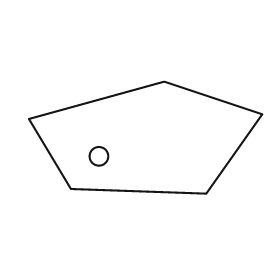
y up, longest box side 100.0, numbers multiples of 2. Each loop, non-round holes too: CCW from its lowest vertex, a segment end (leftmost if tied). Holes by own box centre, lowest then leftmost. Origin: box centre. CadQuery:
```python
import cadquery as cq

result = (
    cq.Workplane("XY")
    .moveTo(26.0, -24.0)
    .lineTo(50.0, 10.0)
    .lineTo(8.0, 24.0)
    .lineTo(-50.0, 8.0)
    .lineTo(-32.0, -22.0)
    .close()
    .moveTo(-20.0, -8.0)
    .circle(4.0)
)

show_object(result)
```